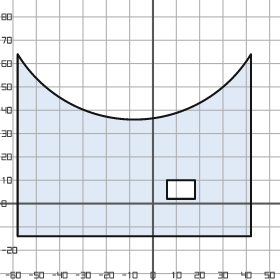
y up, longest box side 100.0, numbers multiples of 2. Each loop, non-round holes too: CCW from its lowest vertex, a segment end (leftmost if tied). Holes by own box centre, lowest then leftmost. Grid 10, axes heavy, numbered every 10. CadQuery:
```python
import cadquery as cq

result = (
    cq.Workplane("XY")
    .moveTo(-58.0, -14.0)
    .lineTo(42.0, -14.0)
    .lineTo(42.0, 64.0)
    .threePointArc((-8.0, 36.0), (-58.0, 64.0))
    .close()
    .moveTo(6.0, 2.0)
    .lineTo(18.0, 2.0)
    .lineTo(18.0, 10.0)
    .lineTo(6.0, 10.0)
    .close()
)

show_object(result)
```